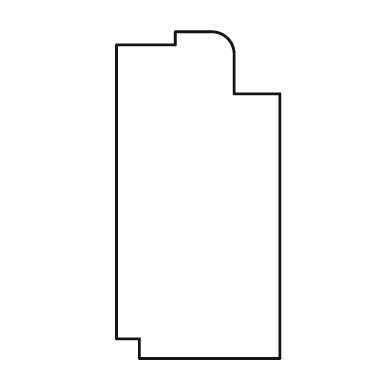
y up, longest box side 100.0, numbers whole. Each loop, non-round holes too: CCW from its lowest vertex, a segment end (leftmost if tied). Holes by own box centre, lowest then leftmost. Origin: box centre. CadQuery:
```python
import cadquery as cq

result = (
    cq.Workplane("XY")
    .moveTo(-18.0, -50.0)
    .lineTo(25.0, -50.0)
    .lineTo(25.0, 31.0)
    .lineTo(11.0, 31.0)
    .lineTo(11.0, 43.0)
    .threePointArc((9.0, 48.0), (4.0, 50.0))
    .lineTo(-7.0, 50.0)
    .lineTo(-7.0, 46.0)
    .lineTo(-25.0, 46.0)
    .lineTo(-25.0, -44.0)
    .lineTo(-18.0, -44.0)
    .close()
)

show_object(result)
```